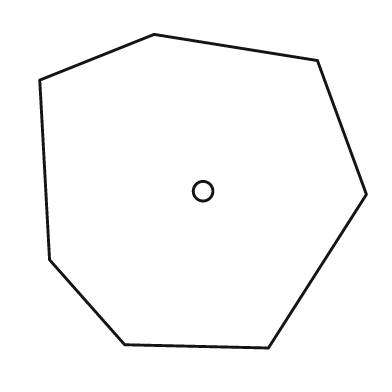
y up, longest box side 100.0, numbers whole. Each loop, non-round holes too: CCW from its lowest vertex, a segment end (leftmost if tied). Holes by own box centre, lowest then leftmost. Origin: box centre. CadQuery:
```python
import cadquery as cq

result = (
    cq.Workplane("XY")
    .moveTo(20.0, -48.0)
    .lineTo(50.0, -1.0)
    .lineTo(35.0, 40.0)
    .lineTo(-15.0, 48.0)
    .lineTo(-50.0, 34.0)
    .lineTo(-47.0, -21.0)
    .lineTo(-24.0, -47.0)
    .close()
    .moveTo(0.0, 0.0)
    .circle(3.0)
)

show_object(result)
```